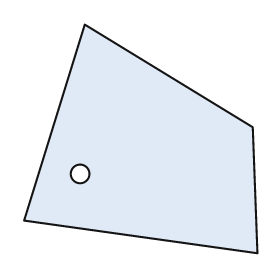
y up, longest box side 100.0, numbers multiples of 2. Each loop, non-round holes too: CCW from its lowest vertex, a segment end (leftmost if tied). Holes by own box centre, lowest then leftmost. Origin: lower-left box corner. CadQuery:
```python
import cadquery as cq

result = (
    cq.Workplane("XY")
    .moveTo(100.0, 0.0)
    .lineTo(98.0, 54.0)
    .lineTo(26.0, 98.0)
    .lineTo(0.0, 14.0)
    .close()
    .moveTo(24.0, 34.0)
    .circle(4.0)
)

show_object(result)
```